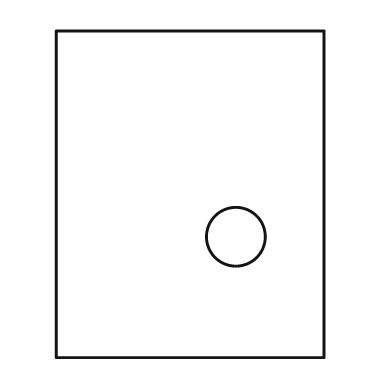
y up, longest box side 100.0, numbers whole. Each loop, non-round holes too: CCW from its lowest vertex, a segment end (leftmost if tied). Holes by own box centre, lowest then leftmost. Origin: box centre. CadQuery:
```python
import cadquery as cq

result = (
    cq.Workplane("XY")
    .moveTo(-41.0, -50.0)
    .lineTo(41.0, -50.0)
    .lineTo(41.0, 50.0)
    .lineTo(-41.0, 50.0)
    .close()
    .moveTo(14.0, -13.0)
    .circle(9.0)
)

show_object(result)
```